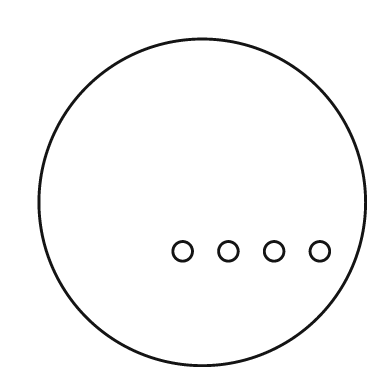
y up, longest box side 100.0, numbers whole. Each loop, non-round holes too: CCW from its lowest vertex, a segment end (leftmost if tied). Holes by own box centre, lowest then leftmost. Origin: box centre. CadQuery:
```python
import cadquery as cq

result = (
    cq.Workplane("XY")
    .moveTo(0.0, 0.0)
    .circle(50.0)
    .moveTo(-6.0, -15.0)
    .circle(3.0)
    .moveTo(8.0, -15.0)
    .circle(3.0)
    .moveTo(22.0, -15.0)
    .circle(3.0)
    .moveTo(36.0, -15.0)
    .circle(3.0)
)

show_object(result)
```